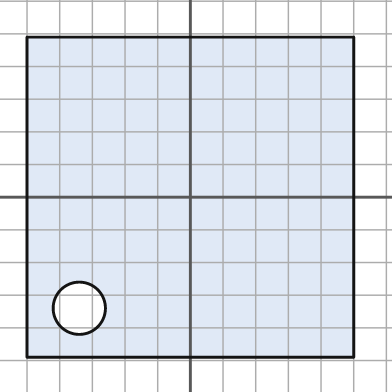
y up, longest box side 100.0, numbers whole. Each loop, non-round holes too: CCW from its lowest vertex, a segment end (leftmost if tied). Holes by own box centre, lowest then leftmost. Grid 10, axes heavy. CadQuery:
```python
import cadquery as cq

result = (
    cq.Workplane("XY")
    .moveTo(-50.0, -49.0)
    .lineTo(50.0, -49.0)
    .lineTo(50.0, 49.0)
    .lineTo(-50.0, 49.0)
    .close()
    .moveTo(-34.0, -34.0)
    .circle(8.0)
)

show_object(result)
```